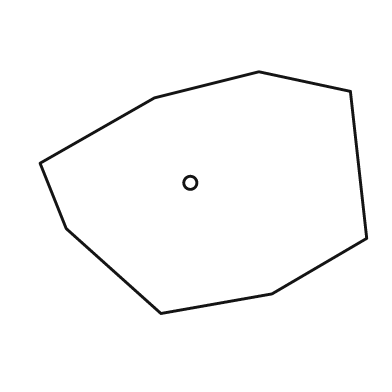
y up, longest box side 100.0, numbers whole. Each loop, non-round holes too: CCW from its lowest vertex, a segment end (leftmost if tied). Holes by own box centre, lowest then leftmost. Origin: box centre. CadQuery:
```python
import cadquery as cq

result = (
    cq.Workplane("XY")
    .moveTo(-13.0, -37.0)
    .lineTo(21.0, -31.0)
    .lineTo(50.0, -14.0)
    .lineTo(45.0, 31.0)
    .lineTo(17.0, 37.0)
    .lineTo(-15.0, 29.0)
    .lineTo(-50.0, 9.0)
    .lineTo(-42.0, -11.0)
    .close()
    .moveTo(-4.0, 3.0)
    .circle(2.0)
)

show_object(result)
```